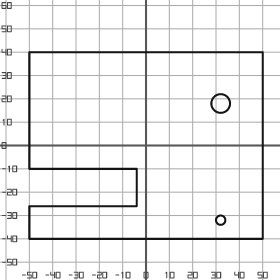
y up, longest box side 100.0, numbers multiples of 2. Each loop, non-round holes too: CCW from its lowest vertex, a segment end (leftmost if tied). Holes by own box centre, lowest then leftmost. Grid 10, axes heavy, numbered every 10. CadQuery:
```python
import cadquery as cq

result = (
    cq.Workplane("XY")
    .moveTo(-50.0, -40.0)
    .lineTo(50.0, -40.0)
    .lineTo(50.0, 40.0)
    .lineTo(-50.0, 40.0)
    .lineTo(-50.0, -10.0)
    .lineTo(-4.0, -10.0)
    .lineTo(-4.0, -26.0)
    .lineTo(-50.0, -26.0)
    .close()
    .moveTo(32.0, -32.0)
    .circle(2.0)
    .moveTo(32.0, 18.0)
    .circle(4.0)
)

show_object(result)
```